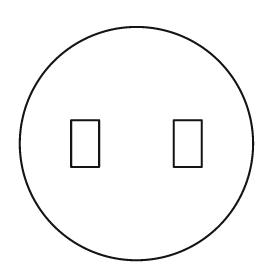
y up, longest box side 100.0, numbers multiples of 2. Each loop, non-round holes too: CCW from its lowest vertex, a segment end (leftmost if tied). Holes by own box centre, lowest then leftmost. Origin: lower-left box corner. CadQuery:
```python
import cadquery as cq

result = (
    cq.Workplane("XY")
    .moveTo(50.0, 50.0)
    .circle(50.0)
    .moveTo(22.0, 40.0)
    .lineTo(34.0, 40.0)
    .lineTo(34.0, 60.0)
    .lineTo(22.0, 60.0)
    .close()
    .moveTo(66.0, 40.0)
    .lineTo(78.0, 40.0)
    .lineTo(78.0, 60.0)
    .lineTo(66.0, 60.0)
    .close()
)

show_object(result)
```